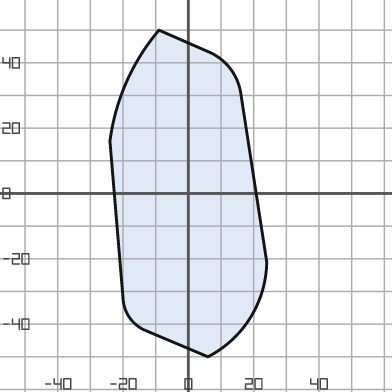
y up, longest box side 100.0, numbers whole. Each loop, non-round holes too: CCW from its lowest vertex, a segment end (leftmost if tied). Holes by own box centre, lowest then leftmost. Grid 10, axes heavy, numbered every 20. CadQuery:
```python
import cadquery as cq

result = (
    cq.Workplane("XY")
    .moveTo(6.0, -50.0)
    .threePointArc((19.0, -38.0), (24.0, -21.0))
    .lineTo(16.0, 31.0)
    .threePointArc((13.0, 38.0), (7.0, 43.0))
    .lineTo(-9.0, 50.0)
    .threePointArc((-19.0, 34.0), (-24.0, 16.0))
    .lineTo(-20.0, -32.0)
    .threePointArc((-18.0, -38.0), (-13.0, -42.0))
    .close()
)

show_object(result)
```